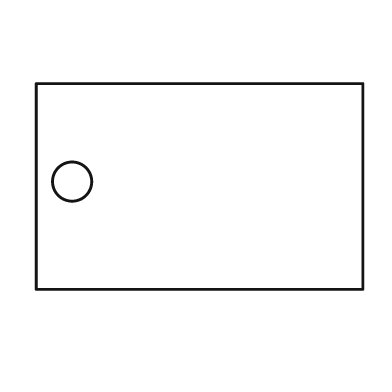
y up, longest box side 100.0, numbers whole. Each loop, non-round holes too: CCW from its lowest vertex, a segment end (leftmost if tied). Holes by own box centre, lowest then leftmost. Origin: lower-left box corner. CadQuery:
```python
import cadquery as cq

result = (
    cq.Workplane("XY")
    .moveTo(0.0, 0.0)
    .lineTo(100.0, 0.0)
    .lineTo(100.0, 63.0)
    .lineTo(0.0, 63.0)
    .close()
    .moveTo(11.0, 33.0)
    .circle(6.0)
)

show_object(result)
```